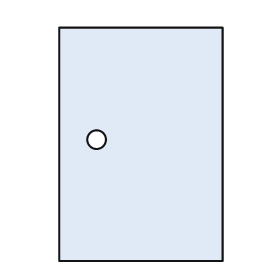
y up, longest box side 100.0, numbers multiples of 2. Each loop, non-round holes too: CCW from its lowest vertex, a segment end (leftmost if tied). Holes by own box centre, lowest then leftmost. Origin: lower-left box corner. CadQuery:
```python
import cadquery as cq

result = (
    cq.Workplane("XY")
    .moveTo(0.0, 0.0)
    .lineTo(70.0, 0.0)
    .lineTo(70.0, 100.0)
    .lineTo(0.0, 100.0)
    .close()
    .moveTo(16.0, 52.0)
    .circle(4.0)
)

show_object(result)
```